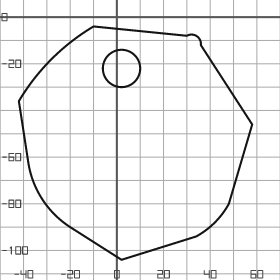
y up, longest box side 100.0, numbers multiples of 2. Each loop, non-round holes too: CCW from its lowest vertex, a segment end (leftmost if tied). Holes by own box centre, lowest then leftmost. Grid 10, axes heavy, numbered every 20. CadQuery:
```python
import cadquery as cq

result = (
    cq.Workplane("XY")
    .moveTo(2.0, -104.0)
    .lineTo(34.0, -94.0)
    .threePointArc((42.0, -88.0), (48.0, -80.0))
    .lineTo(58.0, -46.0)
    .lineTo(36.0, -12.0)
    .threePointArc((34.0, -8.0), (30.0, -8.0))
    .lineTo(-10.0, -4.0)
    .threePointArc((-28.0, -18.0), (-42.0, -36.0))
    .lineTo(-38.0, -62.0)
    .threePointArc((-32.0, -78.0), (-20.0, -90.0))
    .close()
    .moveTo(2.0, -22.0)
    .circle(8.0)
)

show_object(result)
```